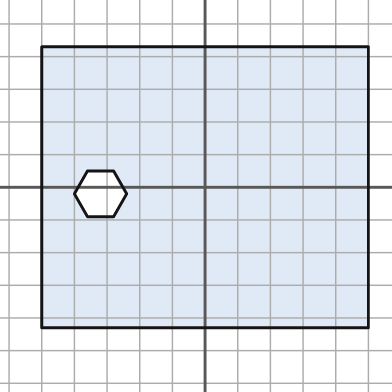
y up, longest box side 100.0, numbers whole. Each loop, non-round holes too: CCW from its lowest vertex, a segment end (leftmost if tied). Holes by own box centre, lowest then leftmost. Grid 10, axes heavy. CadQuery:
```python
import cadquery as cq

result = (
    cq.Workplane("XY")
    .moveTo(-50.0, -43.0)
    .lineTo(50.0, -43.0)
    .lineTo(50.0, 43.0)
    .lineTo(-50.0, 43.0)
    .close()
    .moveTo(-36.0, -9.0)
    .lineTo(-28.0, -9.0)
    .lineTo(-24.0, -2.0)
    .lineTo(-28.0, 5.0)
    .lineTo(-36.0, 5.0)
    .lineTo(-40.0, -2.0)
    .close()
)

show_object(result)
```